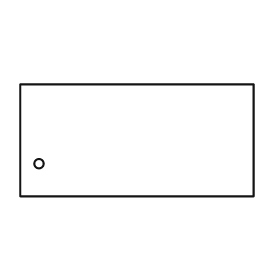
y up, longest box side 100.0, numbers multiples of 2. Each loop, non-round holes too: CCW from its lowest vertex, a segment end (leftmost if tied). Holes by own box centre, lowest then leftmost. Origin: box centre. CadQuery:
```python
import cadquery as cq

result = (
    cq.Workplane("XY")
    .moveTo(-50.0, -24.0)
    .lineTo(50.0, -24.0)
    .lineTo(50.0, 24.0)
    .lineTo(-50.0, 24.0)
    .close()
    .moveTo(-42.0, -10.0)
    .circle(2.0)
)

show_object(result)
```